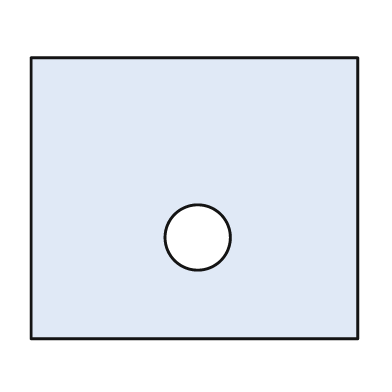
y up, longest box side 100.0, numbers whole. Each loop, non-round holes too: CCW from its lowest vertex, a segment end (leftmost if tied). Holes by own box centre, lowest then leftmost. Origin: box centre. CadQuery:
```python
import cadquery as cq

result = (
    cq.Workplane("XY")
    .moveTo(-50.0, -43.0)
    .lineTo(50.0, -43.0)
    .lineTo(50.0, 43.0)
    .lineTo(-50.0, 43.0)
    .close()
    .moveTo(1.0, -12.0)
    .circle(10.0)
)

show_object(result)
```